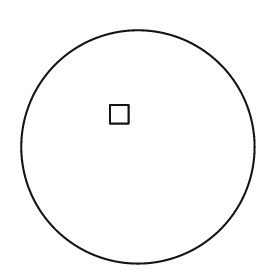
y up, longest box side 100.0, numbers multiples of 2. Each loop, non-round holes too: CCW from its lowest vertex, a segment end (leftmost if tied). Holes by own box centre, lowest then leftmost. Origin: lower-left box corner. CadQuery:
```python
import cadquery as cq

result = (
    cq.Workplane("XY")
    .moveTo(50.0, 50.0)
    .circle(50.0)
    .moveTo(38.0, 60.0)
    .lineTo(46.0, 60.0)
    .lineTo(46.0, 68.0)
    .lineTo(38.0, 68.0)
    .close()
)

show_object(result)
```